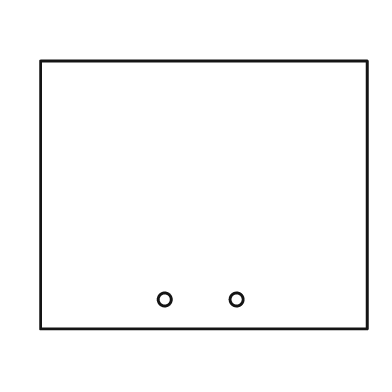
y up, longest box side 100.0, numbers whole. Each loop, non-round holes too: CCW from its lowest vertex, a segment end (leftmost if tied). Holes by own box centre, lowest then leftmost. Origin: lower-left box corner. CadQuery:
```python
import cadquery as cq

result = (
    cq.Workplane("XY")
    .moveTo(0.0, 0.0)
    .lineTo(100.0, 0.0)
    .lineTo(100.0, 82.0)
    .lineTo(0.0, 82.0)
    .close()
    .moveTo(38.0, 9.0)
    .circle(2.0)
    .moveTo(60.0, 9.0)
    .circle(2.0)
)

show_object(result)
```